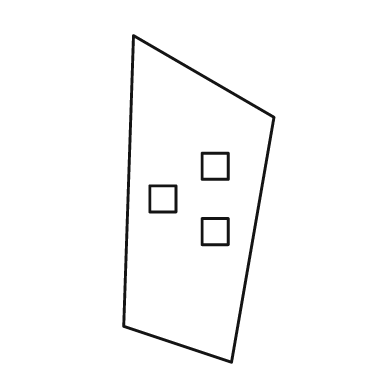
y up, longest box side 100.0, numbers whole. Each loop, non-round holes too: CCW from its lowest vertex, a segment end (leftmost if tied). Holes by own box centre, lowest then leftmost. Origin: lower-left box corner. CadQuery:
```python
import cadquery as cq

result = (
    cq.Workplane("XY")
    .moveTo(33.0, 0.0)
    .lineTo(46.0, 75.0)
    .lineTo(3.0, 100.0)
    .lineTo(0.0, 11.0)
    .close()
    .moveTo(24.0, 36.0)
    .lineTo(32.0, 36.0)
    .lineTo(32.0, 44.0)
    .lineTo(24.0, 44.0)
    .close()
    .moveTo(8.0, 46.0)
    .lineTo(16.0, 46.0)
    .lineTo(16.0, 54.0)
    .lineTo(8.0, 54.0)
    .close()
    .moveTo(24.0, 56.0)
    .lineTo(32.0, 56.0)
    .lineTo(32.0, 64.0)
    .lineTo(24.0, 64.0)
    .close()
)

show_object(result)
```